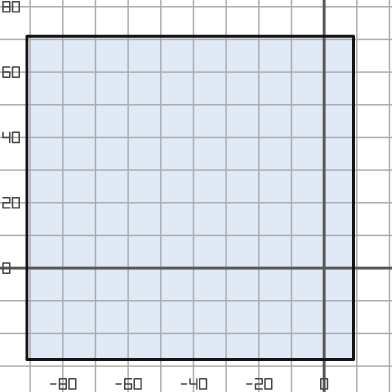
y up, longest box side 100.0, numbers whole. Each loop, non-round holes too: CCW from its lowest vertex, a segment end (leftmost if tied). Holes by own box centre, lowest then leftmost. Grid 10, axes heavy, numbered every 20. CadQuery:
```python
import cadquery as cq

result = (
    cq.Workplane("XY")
    .moveTo(-91.0, -28.0)
    .lineTo(9.0, -28.0)
    .lineTo(9.0, 71.0)
    .lineTo(-91.0, 71.0)
    .close()
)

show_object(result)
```